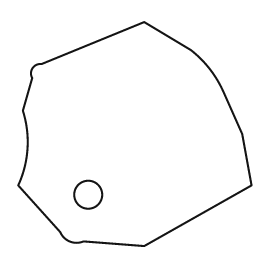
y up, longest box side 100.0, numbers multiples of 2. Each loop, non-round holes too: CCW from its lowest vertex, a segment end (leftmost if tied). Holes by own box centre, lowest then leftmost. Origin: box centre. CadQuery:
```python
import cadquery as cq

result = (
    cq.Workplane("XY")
    .moveTo(4.0, -48.0)
    .lineTo(50.0, -22.0)
    .lineTo(46.0, 0.0)
    .lineTo(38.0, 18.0)
    .threePointArc((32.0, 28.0), (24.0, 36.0))
    .lineTo(4.0, 48.0)
    .lineTo(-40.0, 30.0)
    .threePointArc((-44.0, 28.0), (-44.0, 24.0))
    .lineTo(-48.0, 10.0)
    .threePointArc((-46.0, -6.0), (-50.0, -22.0))
    .lineTo(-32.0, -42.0)
    .threePointArc((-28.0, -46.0), (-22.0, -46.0))
    .close()
    .moveTo(-20.0, -26.0)
    .circle(6.0)
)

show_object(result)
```